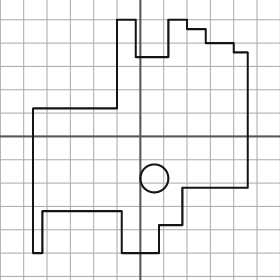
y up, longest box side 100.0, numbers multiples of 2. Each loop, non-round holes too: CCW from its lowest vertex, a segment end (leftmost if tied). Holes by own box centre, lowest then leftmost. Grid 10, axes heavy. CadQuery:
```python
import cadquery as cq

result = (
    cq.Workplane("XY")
    .moveTo(-46.0, -50.0)
    .lineTo(-42.0, -50.0)
    .lineTo(-42.0, -32.0)
    .lineTo(-8.0, -32.0)
    .lineTo(-8.0, -50.0)
    .lineTo(8.0, -50.0)
    .lineTo(8.0, -38.0)
    .lineTo(18.0, -38.0)
    .lineTo(18.0, -22.0)
    .lineTo(46.0, -22.0)
    .lineTo(46.0, 36.0)
    .lineTo(40.0, 36.0)
    .lineTo(40.0, 40.0)
    .lineTo(28.0, 40.0)
    .lineTo(28.0, 46.0)
    .lineTo(20.0, 46.0)
    .lineTo(20.0, 50.0)
    .lineTo(12.0, 50.0)
    .lineTo(12.0, 34.0)
    .lineTo(-2.0, 34.0)
    .lineTo(-2.0, 50.0)
    .lineTo(-10.0, 50.0)
    .lineTo(-10.0, 12.0)
    .lineTo(-46.0, 12.0)
    .close()
    .moveTo(6.0, -18.0)
    .circle(6.0)
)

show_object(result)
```